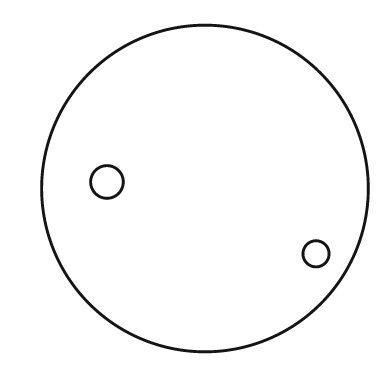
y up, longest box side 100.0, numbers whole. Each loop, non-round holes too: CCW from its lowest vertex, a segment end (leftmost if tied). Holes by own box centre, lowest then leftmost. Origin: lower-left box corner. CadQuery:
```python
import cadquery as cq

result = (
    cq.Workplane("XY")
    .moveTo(50.0, 50.0)
    .circle(50.0)
    .moveTo(84.0, 30.0)
    .circle(4.0)
    .moveTo(20.0, 52.0)
    .circle(5.0)
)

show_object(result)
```